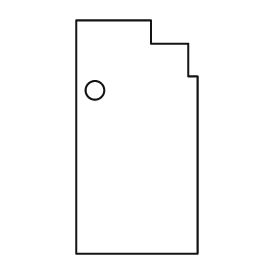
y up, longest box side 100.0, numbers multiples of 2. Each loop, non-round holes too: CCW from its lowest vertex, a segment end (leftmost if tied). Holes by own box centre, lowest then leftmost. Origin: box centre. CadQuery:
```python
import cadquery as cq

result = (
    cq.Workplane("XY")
    .moveTo(-26.0, -50.0)
    .lineTo(26.0, -50.0)
    .lineTo(26.0, 26.0)
    .lineTo(22.0, 26.0)
    .lineTo(22.0, 40.0)
    .lineTo(6.0, 40.0)
    .lineTo(6.0, 50.0)
    .lineTo(-26.0, 50.0)
    .close()
    .moveTo(-18.0, 20.0)
    .circle(4.0)
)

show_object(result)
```